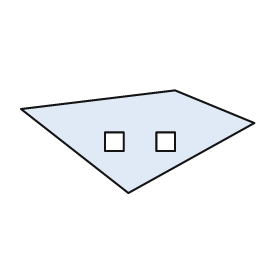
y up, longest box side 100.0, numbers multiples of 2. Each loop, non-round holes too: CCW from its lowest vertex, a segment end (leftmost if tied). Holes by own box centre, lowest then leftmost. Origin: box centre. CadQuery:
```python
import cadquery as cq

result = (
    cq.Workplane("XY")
    .moveTo(-4.0, -22.0)
    .lineTo(50.0, 8.0)
    .lineTo(16.0, 22.0)
    .lineTo(-50.0, 14.0)
    .close()
    .moveTo(-14.0, -4.0)
    .lineTo(-6.0, -4.0)
    .lineTo(-6.0, 4.0)
    .lineTo(-14.0, 4.0)
    .close()
    .moveTo(8.0, -4.0)
    .lineTo(16.0, -4.0)
    .lineTo(16.0, 4.0)
    .lineTo(8.0, 4.0)
    .close()
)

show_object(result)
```